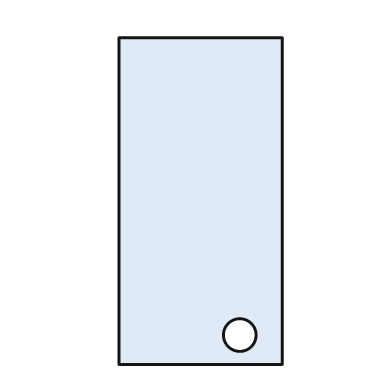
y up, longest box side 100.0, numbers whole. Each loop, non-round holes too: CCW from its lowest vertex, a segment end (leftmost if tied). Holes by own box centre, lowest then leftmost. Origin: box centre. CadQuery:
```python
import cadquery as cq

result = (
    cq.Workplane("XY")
    .moveTo(-25.0, -50.0)
    .lineTo(25.0, -50.0)
    .lineTo(25.0, 50.0)
    .lineTo(-25.0, 50.0)
    .close()
    .moveTo(12.0, -41.0)
    .circle(5.0)
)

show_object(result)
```